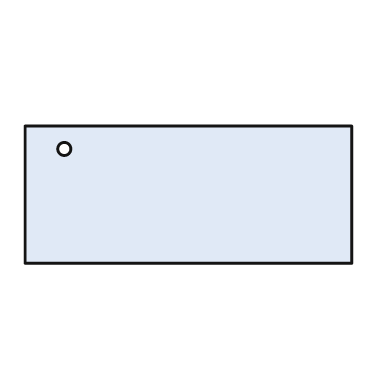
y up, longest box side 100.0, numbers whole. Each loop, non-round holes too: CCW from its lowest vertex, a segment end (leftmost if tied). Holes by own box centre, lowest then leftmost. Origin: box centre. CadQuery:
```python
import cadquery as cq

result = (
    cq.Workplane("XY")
    .moveTo(-50.0, -21.0)
    .lineTo(50.0, -21.0)
    .lineTo(50.0, 21.0)
    .lineTo(-50.0, 21.0)
    .close()
    .moveTo(-38.0, 14.0)
    .circle(2.0)
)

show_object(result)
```